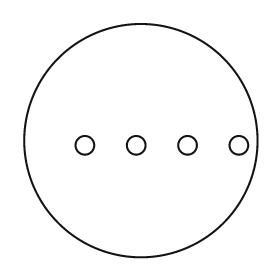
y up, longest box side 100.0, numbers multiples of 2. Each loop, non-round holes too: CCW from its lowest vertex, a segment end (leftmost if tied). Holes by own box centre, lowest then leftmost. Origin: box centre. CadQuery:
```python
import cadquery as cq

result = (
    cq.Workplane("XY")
    .moveTo(0.0, 0.0)
    .circle(50.0)
    .moveTo(-24.0, -2.0)
    .circle(4.0)
    .moveTo(-2.0, -2.0)
    .circle(4.0)
    .moveTo(20.0, -2.0)
    .circle(4.0)
    .moveTo(42.0, -2.0)
    .circle(4.0)
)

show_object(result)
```